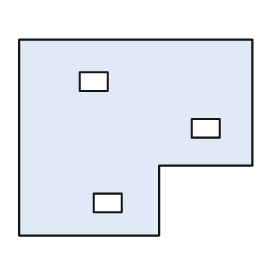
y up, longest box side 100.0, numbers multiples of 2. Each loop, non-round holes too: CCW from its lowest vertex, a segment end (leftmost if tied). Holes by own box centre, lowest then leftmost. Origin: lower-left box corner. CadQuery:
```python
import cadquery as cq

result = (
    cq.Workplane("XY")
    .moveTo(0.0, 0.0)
    .lineTo(60.0, 0.0)
    .lineTo(60.0, 30.0)
    .lineTo(100.0, 30.0)
    .lineTo(100.0, 84.0)
    .lineTo(0.0, 84.0)
    .close()
    .moveTo(32.0, 10.0)
    .lineTo(44.0, 10.0)
    .lineTo(44.0, 18.0)
    .lineTo(32.0, 18.0)
    .close()
    .moveTo(74.0, 42.0)
    .lineTo(86.0, 42.0)
    .lineTo(86.0, 50.0)
    .lineTo(74.0, 50.0)
    .close()
    .moveTo(26.0, 62.0)
    .lineTo(38.0, 62.0)
    .lineTo(38.0, 70.0)
    .lineTo(26.0, 70.0)
    .close()
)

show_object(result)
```